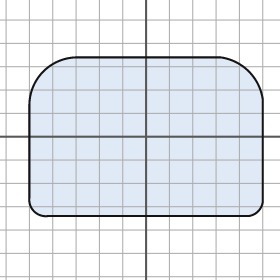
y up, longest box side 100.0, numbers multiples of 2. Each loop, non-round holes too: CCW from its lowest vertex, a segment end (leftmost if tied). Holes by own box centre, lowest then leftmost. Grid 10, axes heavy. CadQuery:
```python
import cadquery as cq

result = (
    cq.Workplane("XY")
    .moveTo(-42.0, -34.0)
    .lineTo(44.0, -34.0)
    .threePointArc((48.0, -32.0), (50.0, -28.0))
    .lineTo(50.0, 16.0)
    .threePointArc((44.0, 28.0), (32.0, 34.0))
    .lineTo(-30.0, 34.0)
    .threePointArc((-44.0, 28.0), (-50.0, 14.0))
    .lineTo(-50.0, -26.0)
    .threePointArc((-48.0, -32.0), (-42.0, -34.0))
    .close()
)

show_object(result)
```